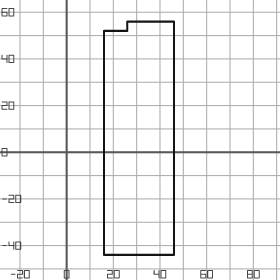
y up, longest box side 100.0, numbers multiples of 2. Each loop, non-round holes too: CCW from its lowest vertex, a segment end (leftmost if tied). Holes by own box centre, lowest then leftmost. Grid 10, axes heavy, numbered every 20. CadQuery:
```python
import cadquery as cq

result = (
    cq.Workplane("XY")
    .moveTo(16.0, -44.0)
    .lineTo(46.0, -44.0)
    .lineTo(46.0, 56.0)
    .lineTo(26.0, 56.0)
    .lineTo(26.0, 52.0)
    .lineTo(16.0, 52.0)
    .close()
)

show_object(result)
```